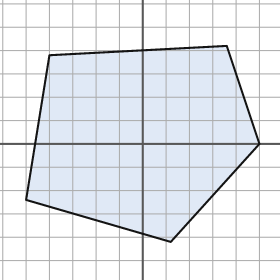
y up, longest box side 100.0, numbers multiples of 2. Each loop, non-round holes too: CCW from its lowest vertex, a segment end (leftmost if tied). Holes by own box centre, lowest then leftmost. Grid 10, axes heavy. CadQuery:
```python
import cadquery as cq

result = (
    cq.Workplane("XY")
    .moveTo(12.0, -42.0)
    .lineTo(50.0, 0.0)
    .lineTo(36.0, 42.0)
    .lineTo(-40.0, 38.0)
    .lineTo(-50.0, -24.0)
    .close()
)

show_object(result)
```